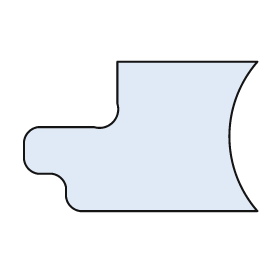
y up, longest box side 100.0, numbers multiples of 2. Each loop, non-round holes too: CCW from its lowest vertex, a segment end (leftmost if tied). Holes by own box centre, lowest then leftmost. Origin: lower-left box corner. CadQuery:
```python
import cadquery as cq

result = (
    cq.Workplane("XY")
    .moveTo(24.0, 0.0)
    .lineTo(100.0, 0.0)
    .threePointArc((88.0, 32.0), (100.0, 64.0))
    .lineTo(40.0, 64.0)
    .lineTo(40.0, 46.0)
    .threePointArc((38.0, 38.0), (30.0, 36.0))
    .lineTo(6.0, 36.0)
    .threePointArc((2.0, 34.0), (0.0, 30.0))
    .lineTo(0.0, 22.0)
    .threePointArc((2.0, 18.0), (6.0, 16.0))
    .lineTo(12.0, 16.0)
    .threePointArc((16.0, 14.0), (18.0, 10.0))
    .lineTo(18.0, 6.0)
    .threePointArc((20.0, 2.0), (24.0, 0.0))
    .close()
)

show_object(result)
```